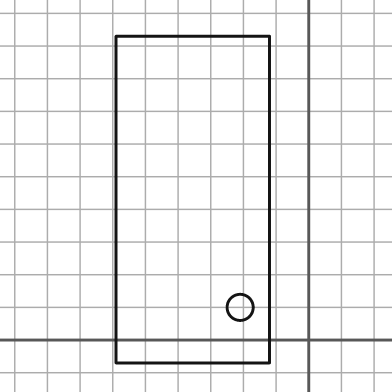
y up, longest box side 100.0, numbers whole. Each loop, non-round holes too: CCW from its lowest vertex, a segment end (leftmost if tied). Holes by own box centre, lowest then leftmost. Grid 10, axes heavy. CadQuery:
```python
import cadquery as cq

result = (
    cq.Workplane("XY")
    .moveTo(-59.0, -7.0)
    .lineTo(-12.0, -7.0)
    .lineTo(-12.0, 93.0)
    .lineTo(-59.0, 93.0)
    .close()
    .moveTo(-21.0, 10.0)
    .circle(4.0)
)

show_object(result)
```